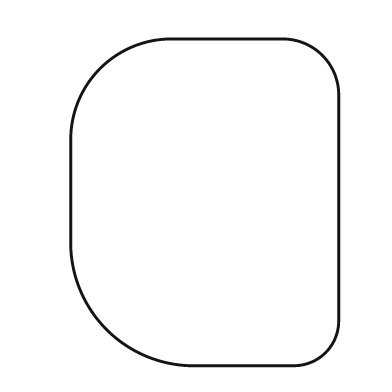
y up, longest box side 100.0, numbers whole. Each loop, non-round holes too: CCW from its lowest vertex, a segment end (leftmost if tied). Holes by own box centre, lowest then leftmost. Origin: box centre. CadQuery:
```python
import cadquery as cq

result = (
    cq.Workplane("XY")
    .moveTo(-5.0, -50.0)
    .lineTo(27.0, -50.0)
    .threePointArc((37.0, -46.0), (41.0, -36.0))
    .lineTo(41.0, 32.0)
    .threePointArc((36.0, 45.0), (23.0, 50.0))
    .lineTo(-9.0, 50.0)
    .threePointArc((-32.0, 41.0), (-41.0, 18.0))
    .lineTo(-41.0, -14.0)
    .threePointArc((-30.0, -39.0), (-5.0, -50.0))
    .close()
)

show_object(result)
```